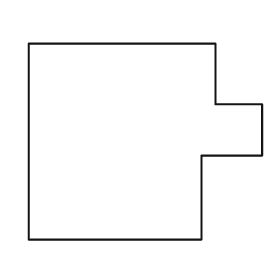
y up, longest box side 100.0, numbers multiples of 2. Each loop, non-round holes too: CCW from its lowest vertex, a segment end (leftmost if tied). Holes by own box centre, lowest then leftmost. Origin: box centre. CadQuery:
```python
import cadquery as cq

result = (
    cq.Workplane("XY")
    .moveTo(-50.0, -42.0)
    .lineTo(24.0, -42.0)
    .lineTo(24.0, -6.0)
    .lineTo(50.0, -6.0)
    .lineTo(50.0, 16.0)
    .lineTo(30.0, 16.0)
    .lineTo(30.0, 42.0)
    .lineTo(-50.0, 42.0)
    .close()
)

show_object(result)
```